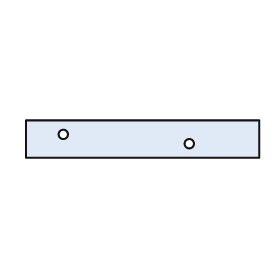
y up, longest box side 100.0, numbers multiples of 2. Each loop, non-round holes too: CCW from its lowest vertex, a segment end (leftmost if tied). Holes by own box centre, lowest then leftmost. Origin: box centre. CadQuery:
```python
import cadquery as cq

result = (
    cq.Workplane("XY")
    .moveTo(-50.0, -8.0)
    .lineTo(50.0, -8.0)
    .lineTo(50.0, 8.0)
    .lineTo(-50.0, 8.0)
    .close()
    .moveTo(20.0, -2.0)
    .circle(2.0)
    .moveTo(-34.0, 2.0)
    .circle(2.0)
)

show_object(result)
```